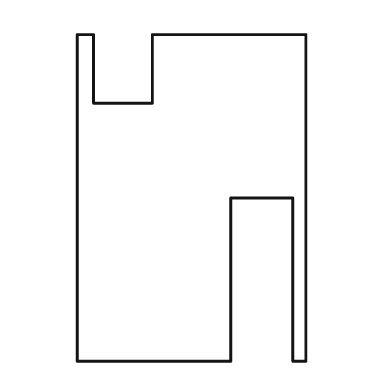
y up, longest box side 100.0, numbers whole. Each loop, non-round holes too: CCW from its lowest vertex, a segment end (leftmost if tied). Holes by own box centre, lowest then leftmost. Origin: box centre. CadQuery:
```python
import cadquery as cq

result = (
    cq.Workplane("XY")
    .moveTo(-35.0, -50.0)
    .lineTo(12.0, -50.0)
    .lineTo(12.0, 0.0)
    .lineTo(31.0, 0.0)
    .lineTo(31.0, -50.0)
    .lineTo(35.0, -50.0)
    .lineTo(35.0, 50.0)
    .lineTo(-12.0, 50.0)
    .lineTo(-12.0, 29.0)
    .lineTo(-30.0, 29.0)
    .lineTo(-30.0, 50.0)
    .lineTo(-35.0, 50.0)
    .close()
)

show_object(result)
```